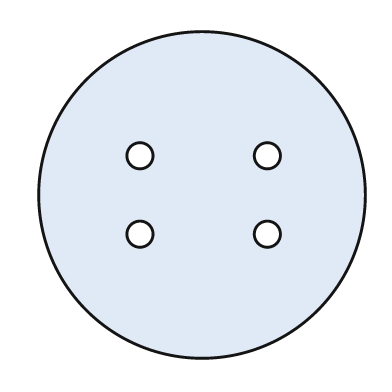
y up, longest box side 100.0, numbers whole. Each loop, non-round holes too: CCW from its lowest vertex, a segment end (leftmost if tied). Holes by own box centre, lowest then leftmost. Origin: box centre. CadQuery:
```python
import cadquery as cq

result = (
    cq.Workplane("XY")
    .moveTo(0.0, 0.0)
    .circle(50.0)
    .moveTo(-19.0, -12.0)
    .circle(4.0)
    .moveTo(20.0, -12.0)
    .circle(4.0)
    .moveTo(-19.0, 12.0)
    .circle(4.0)
    .moveTo(20.0, 12.0)
    .circle(4.0)
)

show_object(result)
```